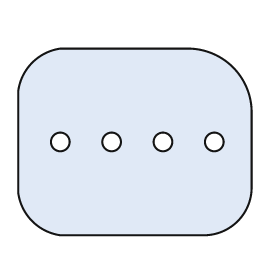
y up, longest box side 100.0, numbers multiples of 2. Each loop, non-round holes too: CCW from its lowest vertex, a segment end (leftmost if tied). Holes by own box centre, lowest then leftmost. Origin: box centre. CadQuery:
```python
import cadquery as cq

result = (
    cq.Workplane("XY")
    .moveTo(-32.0, -40.0)
    .lineTo(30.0, -40.0)
    .threePointArc((44.0, -34.0), (50.0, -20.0))
    .lineTo(50.0, 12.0)
    .threePointArc((42.0, 32.0), (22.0, 40.0))
    .lineTo(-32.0, 40.0)
    .threePointArc((-44.0, 34.0), (-50.0, 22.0))
    .lineTo(-50.0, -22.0)
    .threePointArc((-44.0, -34.0), (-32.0, -40.0))
    .close()
    .moveTo(-32.0, 0.0)
    .circle(4.0)
    .moveTo(-10.0, 0.0)
    .circle(4.0)
    .moveTo(12.0, 0.0)
    .circle(4.0)
    .moveTo(34.0, 0.0)
    .circle(4.0)
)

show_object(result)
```